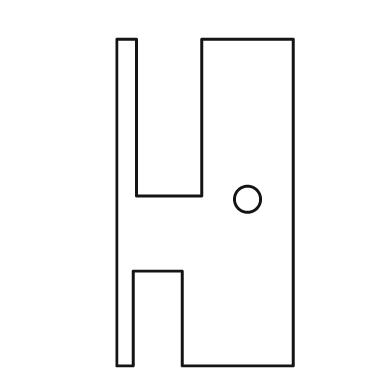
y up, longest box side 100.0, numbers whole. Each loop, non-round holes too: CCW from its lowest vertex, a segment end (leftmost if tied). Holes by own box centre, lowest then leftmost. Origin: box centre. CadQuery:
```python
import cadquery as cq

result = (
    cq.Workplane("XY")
    .moveTo(-27.0, -50.0)
    .lineTo(-22.0, -50.0)
    .lineTo(-22.0, -21.0)
    .lineTo(-7.0, -21.0)
    .lineTo(-7.0, -50.0)
    .lineTo(27.0, -50.0)
    .lineTo(27.0, 50.0)
    .lineTo(-1.0, 50.0)
    .lineTo(-1.0, 2.0)
    .lineTo(-21.0, 2.0)
    .lineTo(-21.0, 50.0)
    .lineTo(-27.0, 50.0)
    .close()
    .moveTo(13.0, 1.0)
    .circle(4.0)
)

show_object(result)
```